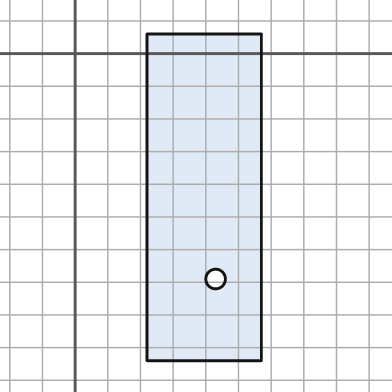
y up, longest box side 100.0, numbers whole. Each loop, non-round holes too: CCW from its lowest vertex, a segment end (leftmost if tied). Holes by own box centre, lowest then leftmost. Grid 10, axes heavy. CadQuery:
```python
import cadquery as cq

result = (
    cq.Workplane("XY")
    .moveTo(22.0, -94.0)
    .lineTo(57.0, -94.0)
    .lineTo(57.0, 6.0)
    .lineTo(22.0, 6.0)
    .close()
    .moveTo(43.0, -69.0)
    .circle(3.0)
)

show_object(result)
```